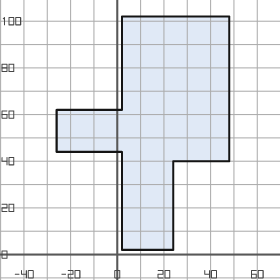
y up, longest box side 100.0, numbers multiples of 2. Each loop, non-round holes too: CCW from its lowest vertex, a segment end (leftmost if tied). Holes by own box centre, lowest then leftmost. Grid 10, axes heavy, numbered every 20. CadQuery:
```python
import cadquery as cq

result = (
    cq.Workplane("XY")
    .moveTo(2.0, 2.0)
    .lineTo(24.0, 2.0)
    .lineTo(24.0, 40.0)
    .lineTo(48.0, 40.0)
    .lineTo(48.0, 102.0)
    .lineTo(2.0, 102.0)
    .lineTo(2.0, 62.0)
    .lineTo(-26.0, 62.0)
    .lineTo(-26.0, 44.0)
    .lineTo(2.0, 44.0)
    .close()
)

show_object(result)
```